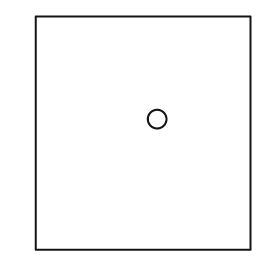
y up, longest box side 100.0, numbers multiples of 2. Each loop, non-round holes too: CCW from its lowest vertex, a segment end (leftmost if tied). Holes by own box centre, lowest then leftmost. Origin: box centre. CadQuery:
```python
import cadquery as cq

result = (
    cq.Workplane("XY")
    .moveTo(-46.0, -50.0)
    .lineTo(46.0, -50.0)
    .lineTo(46.0, 50.0)
    .lineTo(-46.0, 50.0)
    .close()
    .moveTo(6.0, 6.0)
    .circle(4.0)
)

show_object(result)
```